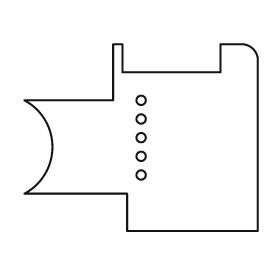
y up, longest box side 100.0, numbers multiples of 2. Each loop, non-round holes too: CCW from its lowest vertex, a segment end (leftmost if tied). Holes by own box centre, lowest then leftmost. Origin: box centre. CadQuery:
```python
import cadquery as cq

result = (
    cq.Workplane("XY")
    .moveTo(-6.0, -40.0)
    .lineTo(50.0, -40.0)
    .lineTo(50.0, 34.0)
    .threePointArc((48.0, 38.0), (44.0, 40.0))
    .lineTo(34.0, 40.0)
    .lineTo(34.0, 28.0)
    .lineTo(-8.0, 28.0)
    .lineTo(-8.0, 40.0)
    .lineTo(-12.0, 40.0)
    .lineTo(-12.0, 16.0)
    .lineTo(-50.0, 16.0)
    .threePointArc((-38.0, -4.0), (-50.0, -24.0))
    .lineTo(-6.0, -24.0)
    .close()
    .moveTo(0.0, -16.0)
    .circle(2.0)
    .moveTo(0.0, -8.0)
    .circle(2.0)
    .moveTo(0.0, 0.0)
    .circle(2.0)
    .moveTo(0.0, 8.0)
    .circle(2.0)
    .moveTo(0.0, 16.0)
    .circle(2.0)
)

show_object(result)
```